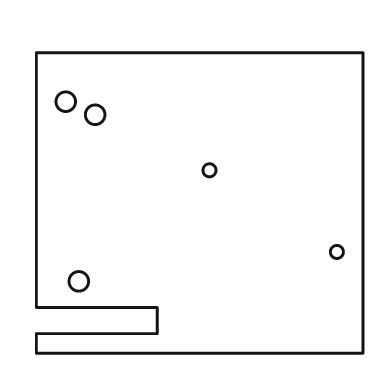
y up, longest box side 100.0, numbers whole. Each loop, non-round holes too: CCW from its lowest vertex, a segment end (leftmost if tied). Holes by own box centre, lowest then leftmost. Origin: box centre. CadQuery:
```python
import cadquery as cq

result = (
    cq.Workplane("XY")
    .moveTo(-50.0, -46.0)
    .lineTo(50.0, -46.0)
    .lineTo(50.0, 46.0)
    .lineTo(-50.0, 46.0)
    .lineTo(-50.0, -32.0)
    .lineTo(-13.0, -32.0)
    .lineTo(-13.0, -40.0)
    .lineTo(-50.0, -40.0)
    .close()
    .moveTo(-37.0, -24.0)
    .circle(3.0)
    .moveTo(42.0, -15.0)
    .circle(2.0)
    .moveTo(3.0, 10.0)
    .circle(2.0)
    .moveTo(-32.0, 27.0)
    .circle(3.0)
    .moveTo(-41.0, 31.0)
    .circle(3.0)
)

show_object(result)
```